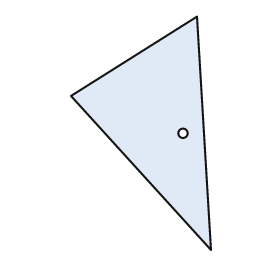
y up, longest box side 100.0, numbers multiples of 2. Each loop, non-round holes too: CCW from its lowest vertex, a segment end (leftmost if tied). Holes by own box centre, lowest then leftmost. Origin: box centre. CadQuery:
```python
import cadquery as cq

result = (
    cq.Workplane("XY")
    .moveTo(30.0, -50.0)
    .lineTo(24.0, 50.0)
    .lineTo(-30.0, 16.0)
    .close()
    .moveTo(18.0, 0.0)
    .circle(2.0)
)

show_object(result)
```